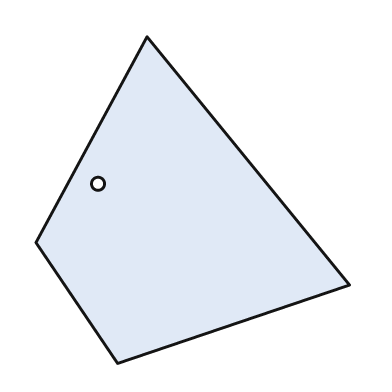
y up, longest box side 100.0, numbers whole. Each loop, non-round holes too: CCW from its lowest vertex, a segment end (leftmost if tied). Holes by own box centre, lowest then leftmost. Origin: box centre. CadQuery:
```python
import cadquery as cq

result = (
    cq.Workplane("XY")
    .moveTo(-23.0, -50.0)
    .lineTo(48.0, -26.0)
    .lineTo(-14.0, 50.0)
    .lineTo(-48.0, -13.0)
    .close()
    .moveTo(-29.0, 5.0)
    .circle(2.0)
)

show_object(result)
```